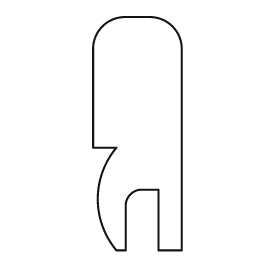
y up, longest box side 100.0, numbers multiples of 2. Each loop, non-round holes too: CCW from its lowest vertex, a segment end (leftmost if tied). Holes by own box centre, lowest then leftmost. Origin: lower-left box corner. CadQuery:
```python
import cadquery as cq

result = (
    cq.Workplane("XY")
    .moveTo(10.0, 0.0)
    .lineTo(14.0, 0.0)
    .lineTo(14.0, 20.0)
    .threePointArc((16.0, 24.0), (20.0, 26.0))
    .lineTo(28.0, 26.0)
    .lineTo(28.0, 0.0)
    .lineTo(38.0, 0.0)
    .lineTo(38.0, 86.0)
    .threePointArc((34.0, 96.0), (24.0, 100.0))
    .lineTo(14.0, 100.0)
    .threePointArc((4.0, 96.0), (0.0, 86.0))
    .lineTo(0.0, 44.0)
    .lineTo(10.0, 44.0)
    .threePointArc((2.0, 22.0), (10.0, 0.0))
    .close()
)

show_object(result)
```